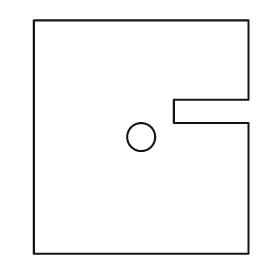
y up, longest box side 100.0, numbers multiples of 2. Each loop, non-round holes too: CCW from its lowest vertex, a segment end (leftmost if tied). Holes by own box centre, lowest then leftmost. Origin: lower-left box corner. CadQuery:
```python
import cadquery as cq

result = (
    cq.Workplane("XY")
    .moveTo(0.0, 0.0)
    .lineTo(92.0, 0.0)
    .lineTo(92.0, 56.0)
    .lineTo(60.0, 56.0)
    .lineTo(60.0, 66.0)
    .lineTo(92.0, 66.0)
    .lineTo(92.0, 100.0)
    .lineTo(0.0, 100.0)
    .close()
    .moveTo(46.0, 50.0)
    .circle(6.0)
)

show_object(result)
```